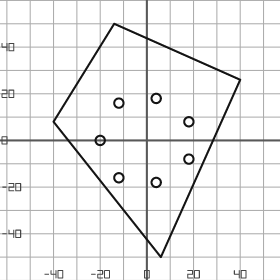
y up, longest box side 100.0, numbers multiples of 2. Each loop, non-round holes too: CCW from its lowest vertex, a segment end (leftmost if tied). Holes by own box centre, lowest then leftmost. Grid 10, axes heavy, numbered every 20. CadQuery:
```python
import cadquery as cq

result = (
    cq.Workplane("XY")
    .moveTo(6.0, -50.0)
    .lineTo(40.0, 26.0)
    .lineTo(-14.0, 50.0)
    .lineTo(-40.0, 8.0)
    .close()
    .moveTo(4.0, -18.0)
    .circle(2.0)
    .moveTo(-12.0, -16.0)
    .circle(2.0)
    .moveTo(18.0, -8.0)
    .circle(2.0)
    .moveTo(-20.0, 0.0)
    .circle(2.0)
    .moveTo(18.0, 8.0)
    .circle(2.0)
    .moveTo(-12.0, 16.0)
    .circle(2.0)
    .moveTo(4.0, 18.0)
    .circle(2.0)
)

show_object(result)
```